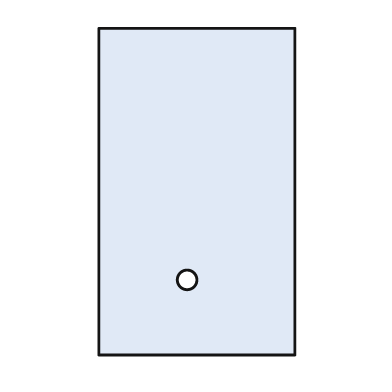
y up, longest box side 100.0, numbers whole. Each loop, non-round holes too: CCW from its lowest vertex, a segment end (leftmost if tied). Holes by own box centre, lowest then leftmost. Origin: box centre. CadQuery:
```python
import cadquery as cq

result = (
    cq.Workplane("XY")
    .moveTo(-30.0, -50.0)
    .lineTo(30.0, -50.0)
    .lineTo(30.0, 50.0)
    .lineTo(-30.0, 50.0)
    .close()
    .moveTo(-3.0, -27.0)
    .circle(3.0)
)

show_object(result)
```